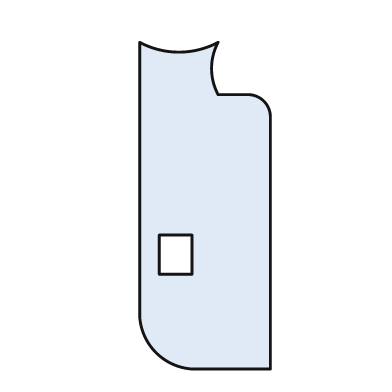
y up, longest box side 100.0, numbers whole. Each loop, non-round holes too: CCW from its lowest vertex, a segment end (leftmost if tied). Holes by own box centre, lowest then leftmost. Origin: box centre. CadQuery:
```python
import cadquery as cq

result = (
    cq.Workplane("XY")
    .moveTo(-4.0, -50.0)
    .lineTo(20.0, -50.0)
    .lineTo(20.0, 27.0)
    .threePointArc((18.0, 32.0), (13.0, 34.0))
    .lineTo(4.0, 34.0)
    .threePointArc((2.0, 42.0), (4.0, 50.0))
    .threePointArc((-8.0, 47.0), (-20.0, 50.0))
    .lineTo(-20.0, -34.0)
    .threePointArc((-15.0, -45.0), (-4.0, -50.0))
    .close()
    .moveTo(-14.0, -21.0)
    .lineTo(-4.0, -21.0)
    .lineTo(-4.0, -9.0)
    .lineTo(-14.0, -9.0)
    .close()
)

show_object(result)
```